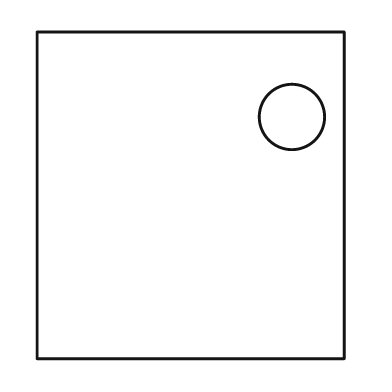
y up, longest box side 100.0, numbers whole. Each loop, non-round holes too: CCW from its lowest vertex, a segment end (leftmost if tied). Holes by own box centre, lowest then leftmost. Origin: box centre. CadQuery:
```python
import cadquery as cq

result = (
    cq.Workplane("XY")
    .moveTo(-47.0, -50.0)
    .lineTo(47.0, -50.0)
    .lineTo(47.0, 50.0)
    .lineTo(-47.0, 50.0)
    .close()
    .moveTo(31.0, 24.0)
    .circle(10.0)
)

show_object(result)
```